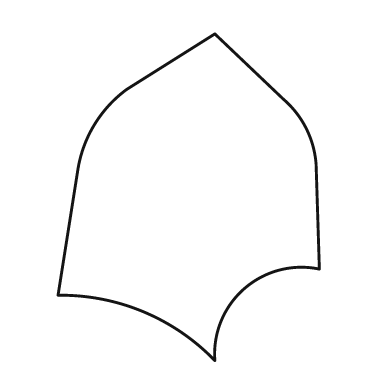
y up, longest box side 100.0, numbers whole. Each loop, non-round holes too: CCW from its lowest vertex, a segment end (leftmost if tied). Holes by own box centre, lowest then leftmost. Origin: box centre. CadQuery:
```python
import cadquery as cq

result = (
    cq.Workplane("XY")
    .moveTo(8.0, -50.0)
    .threePointArc((17.0, -28.0), (40.0, -22.0))
    .lineTo(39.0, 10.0)
    .threePointArc((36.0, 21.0), (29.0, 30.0))
    .lineTo(8.0, 50.0)
    .lineTo(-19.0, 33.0)
    .threePointArc((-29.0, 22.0), (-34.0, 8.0))
    .lineTo(-40.0, -30.0)
    .threePointArc((-14.0, -35.0), (8.0, -50.0))
    .close()
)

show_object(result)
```